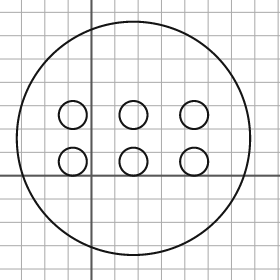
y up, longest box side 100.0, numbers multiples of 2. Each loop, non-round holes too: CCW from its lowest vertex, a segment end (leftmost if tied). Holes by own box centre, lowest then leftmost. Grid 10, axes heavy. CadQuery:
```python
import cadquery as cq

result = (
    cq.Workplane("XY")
    .moveTo(18.0, 16.0)
    .circle(50.0)
    .moveTo(-8.0, 6.0)
    .circle(6.0)
    .moveTo(18.0, 6.0)
    .circle(6.0)
    .moveTo(44.0, 6.0)
    .circle(6.0)
    .moveTo(-8.0, 26.0)
    .circle(6.0)
    .moveTo(18.0, 26.0)
    .circle(6.0)
    .moveTo(44.0, 26.0)
    .circle(6.0)
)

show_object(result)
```